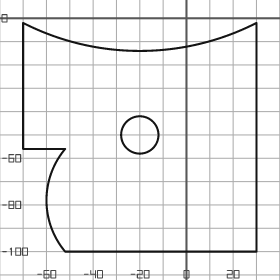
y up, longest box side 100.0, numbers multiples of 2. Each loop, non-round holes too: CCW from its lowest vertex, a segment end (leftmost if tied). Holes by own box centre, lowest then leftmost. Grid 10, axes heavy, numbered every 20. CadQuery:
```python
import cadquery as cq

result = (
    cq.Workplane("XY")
    .moveTo(-52.0, -100.0)
    .lineTo(30.0, -100.0)
    .lineTo(30.0, -2.0)
    .threePointArc((-20.0, -14.0), (-70.0, -2.0))
    .lineTo(-70.0, -56.0)
    .lineTo(-52.0, -56.0)
    .threePointArc((-60.0, -78.0), (-52.0, -100.0))
    .close()
    .moveTo(-20.0, -50.0)
    .circle(8.0)
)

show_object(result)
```